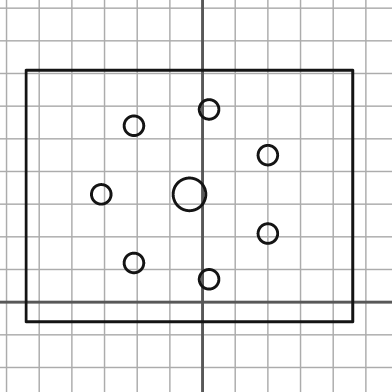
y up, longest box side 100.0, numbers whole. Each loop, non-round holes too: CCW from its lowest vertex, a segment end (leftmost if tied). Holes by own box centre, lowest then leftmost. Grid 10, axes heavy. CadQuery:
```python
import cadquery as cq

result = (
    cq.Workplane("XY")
    .moveTo(-54.0, -6.0)
    .lineTo(46.0, -6.0)
    .lineTo(46.0, 71.0)
    .lineTo(-54.0, 71.0)
    .close()
    .moveTo(2.0, 7.0)
    .circle(3.0)
    .moveTo(-21.0, 12.0)
    .circle(3.0)
    .moveTo(20.0, 21.0)
    .circle(3.0)
    .moveTo(-31.0, 33.0)
    .circle(3.0)
    .moveTo(-4.0, 33.0)
    .circle(5.0)
    .moveTo(20.0, 45.0)
    .circle(3.0)
    .moveTo(-21.0, 54.0)
    .circle(3.0)
    .moveTo(2.0, 59.0)
    .circle(3.0)
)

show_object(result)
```